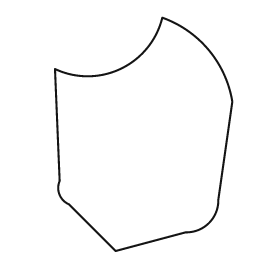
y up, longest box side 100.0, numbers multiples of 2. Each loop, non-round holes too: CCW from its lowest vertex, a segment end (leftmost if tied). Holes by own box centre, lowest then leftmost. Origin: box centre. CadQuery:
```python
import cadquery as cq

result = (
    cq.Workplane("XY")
    .moveTo(-12.0, -50.0)
    .lineTo(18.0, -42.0)
    .threePointArc((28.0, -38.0), (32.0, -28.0))
    .lineTo(38.0, 14.0)
    .threePointArc((28.0, 36.0), (8.0, 50.0))
    .threePointArc((-10.0, 28.0), (-38.0, 28.0))
    .lineTo(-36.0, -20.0)
    .threePointArc((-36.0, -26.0), (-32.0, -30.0))
    .close()
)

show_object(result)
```